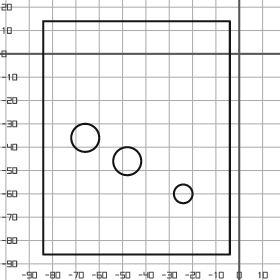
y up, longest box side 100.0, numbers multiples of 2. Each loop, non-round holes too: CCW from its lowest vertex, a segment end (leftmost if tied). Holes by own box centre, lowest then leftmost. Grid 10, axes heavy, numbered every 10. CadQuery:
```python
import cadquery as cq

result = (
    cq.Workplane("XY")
    .moveTo(-84.0, -86.0)
    .lineTo(-4.0, -86.0)
    .lineTo(-4.0, 14.0)
    .lineTo(-84.0, 14.0)
    .close()
    .moveTo(-24.0, -60.0)
    .circle(4.0)
    .moveTo(-48.0, -46.0)
    .circle(6.0)
    .moveTo(-66.0, -36.0)
    .circle(6.0)
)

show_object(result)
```